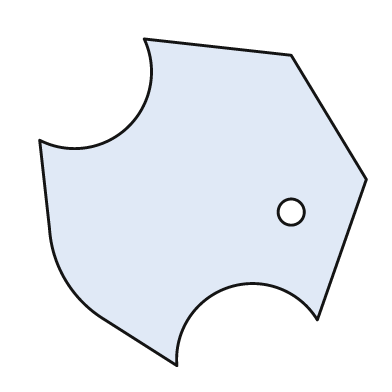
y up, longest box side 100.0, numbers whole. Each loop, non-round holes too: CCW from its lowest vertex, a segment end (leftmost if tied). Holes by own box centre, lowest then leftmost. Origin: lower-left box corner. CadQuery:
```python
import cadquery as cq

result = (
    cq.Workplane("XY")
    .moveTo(42.0, 0.0)
    .threePointArc((58.0, 24.0), (85.0, 14.0))
    .lineTo(100.0, 57.0)
    .lineTo(77.0, 95.0)
    .lineTo(32.0, 100.0)
    .threePointArc((27.0, 73.0), (0.0, 69.0))
    .lineTo(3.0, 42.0)
    .threePointArc((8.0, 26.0), (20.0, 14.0))
    .close()
    .moveTo(77.0, 47.0)
    .circle(4.0)
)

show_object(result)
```